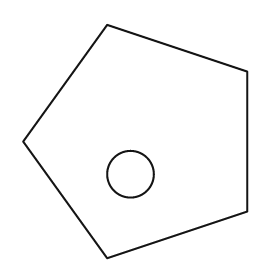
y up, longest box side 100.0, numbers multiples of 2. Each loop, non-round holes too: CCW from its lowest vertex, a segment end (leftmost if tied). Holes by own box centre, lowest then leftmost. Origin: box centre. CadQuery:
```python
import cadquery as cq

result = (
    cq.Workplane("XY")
    .moveTo(-12.0, -50.0)
    .lineTo(48.0, -30.0)
    .lineTo(48.0, 30.0)
    .lineTo(-12.0, 50.0)
    .lineTo(-48.0, 0.0)
    .close()
    .moveTo(-2.0, -14.0)
    .circle(10.0)
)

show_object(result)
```